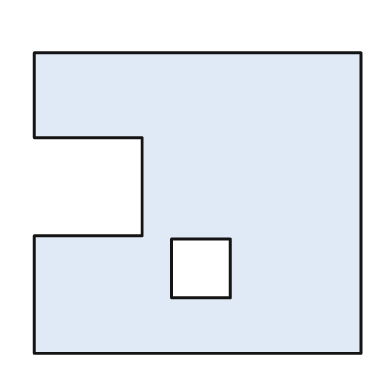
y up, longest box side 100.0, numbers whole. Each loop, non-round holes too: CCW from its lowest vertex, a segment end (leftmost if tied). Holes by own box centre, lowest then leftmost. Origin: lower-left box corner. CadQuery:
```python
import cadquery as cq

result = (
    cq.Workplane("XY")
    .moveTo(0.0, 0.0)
    .lineTo(100.0, 0.0)
    .lineTo(100.0, 92.0)
    .lineTo(0.0, 92.0)
    .lineTo(0.0, 66.0)
    .lineTo(33.0, 66.0)
    .lineTo(33.0, 36.0)
    .lineTo(0.0, 36.0)
    .close()
    .moveTo(42.0, 17.0)
    .lineTo(60.0, 17.0)
    .lineTo(60.0, 35.0)
    .lineTo(42.0, 35.0)
    .close()
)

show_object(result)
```